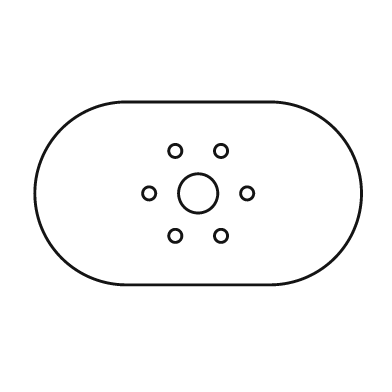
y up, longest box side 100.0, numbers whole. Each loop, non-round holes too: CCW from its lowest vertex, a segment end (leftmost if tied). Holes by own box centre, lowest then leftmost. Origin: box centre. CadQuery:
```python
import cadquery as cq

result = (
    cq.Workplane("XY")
    .moveTo(-22.0, -28.0)
    .lineTo(22.0, -28.0)
    .threePointArc((50.0, 0.0), (22.0, 28.0))
    .lineTo(-22.0, 28.0)
    .threePointArc((-50.0, 0.0), (-22.0, -28.0))
    .close()
    .moveTo(-7.0, -13.0)
    .circle(2.0)
    .moveTo(7.0, -13.0)
    .circle(2.0)
    .moveTo(-15.0, 0.0)
    .circle(2.0)
    .moveTo(0.0, 0.0)
    .circle(6.0)
    .moveTo(15.0, 0.0)
    .circle(2.0)
    .moveTo(-7.0, 13.0)
    .circle(2.0)
    .moveTo(7.0, 13.0)
    .circle(2.0)
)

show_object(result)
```